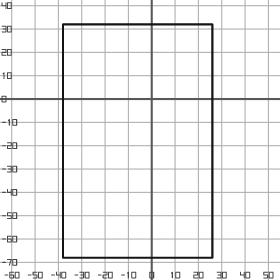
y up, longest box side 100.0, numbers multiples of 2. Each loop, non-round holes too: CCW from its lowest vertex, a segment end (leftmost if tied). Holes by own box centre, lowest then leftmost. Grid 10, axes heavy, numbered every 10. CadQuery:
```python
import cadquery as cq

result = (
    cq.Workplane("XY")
    .moveTo(-38.0, -68.0)
    .lineTo(26.0, -68.0)
    .lineTo(26.0, 32.0)
    .lineTo(-38.0, 32.0)
    .close()
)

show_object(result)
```